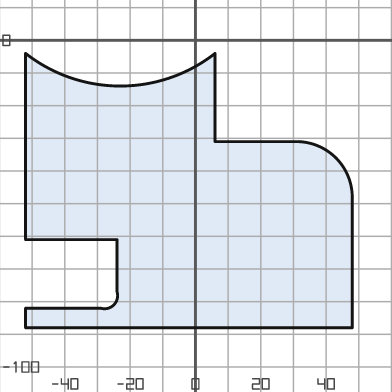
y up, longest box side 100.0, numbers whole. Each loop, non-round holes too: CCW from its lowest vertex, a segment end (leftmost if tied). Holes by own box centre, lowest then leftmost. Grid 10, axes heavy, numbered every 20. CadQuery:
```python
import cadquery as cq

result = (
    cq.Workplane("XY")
    .moveTo(-52.0, -88.0)
    .lineTo(48.0, -88.0)
    .lineTo(48.0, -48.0)
    .threePointArc((43.0, -36.0), (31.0, -31.0))
    .lineTo(6.0, -31.0)
    .lineTo(6.0, -4.0)
    .threePointArc((-23.0, -14.0), (-52.0, -4.0))
    .lineTo(-52.0, -61.0)
    .lineTo(-24.0, -61.0)
    .lineTo(-24.0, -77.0)
    .threePointArc((-25.0, -81.0), (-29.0, -82.0))
    .lineTo(-52.0, -82.0)
    .close()
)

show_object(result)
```